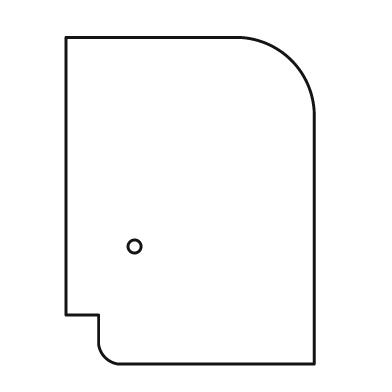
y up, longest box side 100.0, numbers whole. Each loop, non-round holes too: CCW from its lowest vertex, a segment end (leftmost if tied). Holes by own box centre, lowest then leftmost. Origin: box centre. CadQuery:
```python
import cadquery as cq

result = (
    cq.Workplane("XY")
    .moveTo(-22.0, -50.0)
    .lineTo(38.0, -50.0)
    .lineTo(38.0, 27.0)
    .threePointArc((31.0, 43.0), (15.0, 50.0))
    .lineTo(-38.0, 50.0)
    .lineTo(-38.0, -35.0)
    .lineTo(-28.0, -35.0)
    .lineTo(-28.0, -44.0)
    .threePointArc((-26.0, -48.0), (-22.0, -50.0))
    .close()
    .moveTo(-17.0, -14.0)
    .circle(2.0)
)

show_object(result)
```